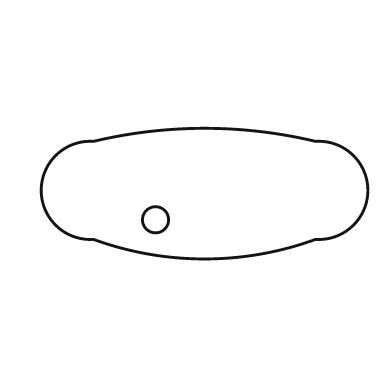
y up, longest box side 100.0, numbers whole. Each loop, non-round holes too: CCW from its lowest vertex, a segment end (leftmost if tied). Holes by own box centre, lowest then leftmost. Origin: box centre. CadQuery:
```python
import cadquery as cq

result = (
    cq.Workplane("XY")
    .moveTo(-34.0, -14.0)
    .threePointArc((0.0, -20.0), (34.0, -14.0))
    .threePointArc((50.0, 1.0), (34.0, 16.0))
    .threePointArc((0.0, 20.0), (-34.0, 16.0))
    .threePointArc((-50.0, 1.0), (-34.0, -14.0))
    .close()
    .moveTo(-15.0, -8.0)
    .circle(4.0)
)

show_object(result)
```